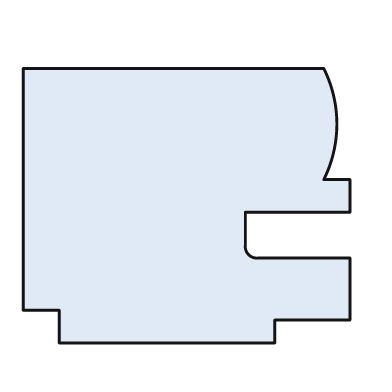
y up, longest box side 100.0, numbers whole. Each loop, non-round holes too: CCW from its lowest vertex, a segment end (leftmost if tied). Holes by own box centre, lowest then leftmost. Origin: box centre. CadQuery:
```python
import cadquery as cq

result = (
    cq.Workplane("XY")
    .moveTo(-39.0, -42.0)
    .lineTo(27.0, -42.0)
    .lineTo(27.0, -35.0)
    .lineTo(50.0, -35.0)
    .lineTo(50.0, -16.0)
    .lineTo(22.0, -16.0)
    .threePointArc((19.0, -15.0), (18.0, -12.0))
    .lineTo(18.0, -2.0)
    .lineTo(50.0, -2.0)
    .lineTo(50.0, 8.0)
    .lineTo(42.0, 8.0)
    .threePointArc((46.0, 25.0), (42.0, 42.0))
    .lineTo(-50.0, 42.0)
    .lineTo(-50.0, -32.0)
    .lineTo(-39.0, -32.0)
    .close()
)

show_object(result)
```